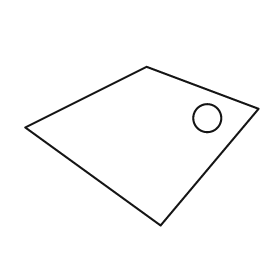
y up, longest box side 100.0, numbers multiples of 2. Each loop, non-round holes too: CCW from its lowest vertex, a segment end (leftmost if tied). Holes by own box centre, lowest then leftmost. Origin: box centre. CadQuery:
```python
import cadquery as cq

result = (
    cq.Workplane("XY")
    .moveTo(8.0, -34.0)
    .lineTo(50.0, 16.0)
    .lineTo(2.0, 34.0)
    .lineTo(-50.0, 8.0)
    .close()
    .moveTo(28.0, 12.0)
    .circle(6.0)
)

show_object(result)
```